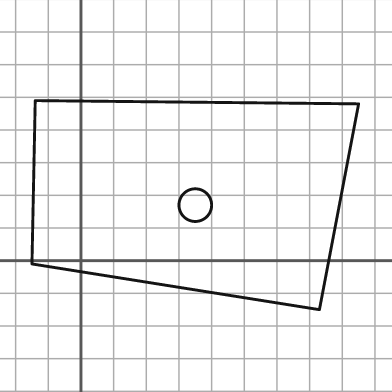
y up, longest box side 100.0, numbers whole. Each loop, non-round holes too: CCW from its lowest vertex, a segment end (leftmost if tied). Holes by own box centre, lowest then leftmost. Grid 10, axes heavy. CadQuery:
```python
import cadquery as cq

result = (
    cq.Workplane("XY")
    .moveTo(73.0, -15.0)
    .lineTo(85.0, 48.0)
    .lineTo(-14.0, 49.0)
    .lineTo(-15.0, -1.0)
    .close()
    .moveTo(35.0, 17.0)
    .circle(5.0)
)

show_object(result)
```